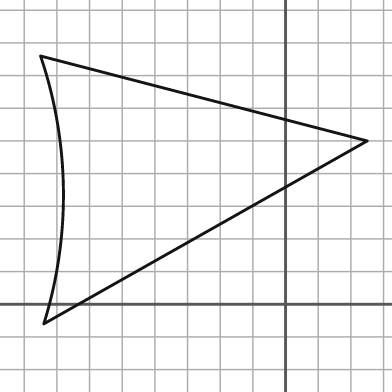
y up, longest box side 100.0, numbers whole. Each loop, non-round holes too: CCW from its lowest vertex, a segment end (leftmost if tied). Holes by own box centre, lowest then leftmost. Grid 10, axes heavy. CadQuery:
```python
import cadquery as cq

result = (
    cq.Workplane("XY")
    .moveTo(-74.0, -6.0)
    .lineTo(25.0, 50.0)
    .lineTo(-75.0, 76.0)
    .threePointArc((-68.0, 35.0), (-74.0, -6.0))
    .close()
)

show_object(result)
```